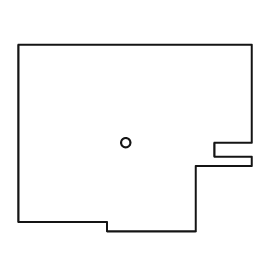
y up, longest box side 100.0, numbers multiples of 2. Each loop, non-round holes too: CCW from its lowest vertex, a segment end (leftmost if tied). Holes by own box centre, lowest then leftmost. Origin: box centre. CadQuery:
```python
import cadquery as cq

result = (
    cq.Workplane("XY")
    .moveTo(-12.0, -40.0)
    .lineTo(26.0, -40.0)
    .lineTo(26.0, -12.0)
    .lineTo(50.0, -12.0)
    .lineTo(50.0, -8.0)
    .lineTo(34.0, -8.0)
    .lineTo(34.0, -2.0)
    .lineTo(50.0, -2.0)
    .lineTo(50.0, 40.0)
    .lineTo(-50.0, 40.0)
    .lineTo(-50.0, -36.0)
    .lineTo(-12.0, -36.0)
    .close()
    .moveTo(-4.0, -2.0)
    .circle(2.0)
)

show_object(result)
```